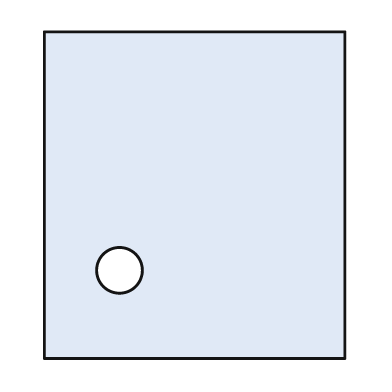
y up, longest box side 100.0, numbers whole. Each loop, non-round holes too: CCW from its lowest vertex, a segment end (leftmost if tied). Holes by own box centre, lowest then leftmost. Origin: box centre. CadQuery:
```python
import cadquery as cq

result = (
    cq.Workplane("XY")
    .moveTo(-46.0, -50.0)
    .lineTo(46.0, -50.0)
    .lineTo(46.0, 50.0)
    .lineTo(-46.0, 50.0)
    .close()
    .moveTo(-23.0, -23.0)
    .circle(7.0)
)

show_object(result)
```